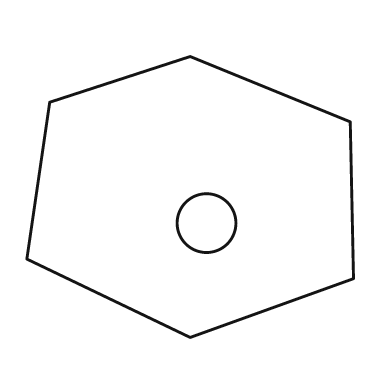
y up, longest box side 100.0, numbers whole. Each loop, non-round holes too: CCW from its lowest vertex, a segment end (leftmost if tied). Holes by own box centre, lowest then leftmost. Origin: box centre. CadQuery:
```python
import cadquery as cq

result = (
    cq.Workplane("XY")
    .moveTo(0.0, -43.0)
    .lineTo(50.0, -25.0)
    .lineTo(49.0, 23.0)
    .lineTo(0.0, 43.0)
    .lineTo(-43.0, 29.0)
    .lineTo(-50.0, -19.0)
    .close()
    .moveTo(5.0, -8.0)
    .circle(9.0)
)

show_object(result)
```